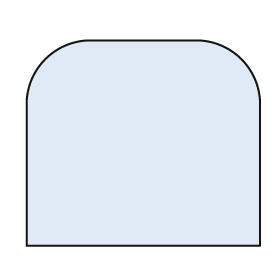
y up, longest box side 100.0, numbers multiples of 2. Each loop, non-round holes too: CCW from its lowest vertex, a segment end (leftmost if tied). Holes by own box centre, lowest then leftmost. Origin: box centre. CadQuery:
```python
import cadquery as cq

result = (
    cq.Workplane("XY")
    .moveTo(-50.0, -44.0)
    .lineTo(50.0, -44.0)
    .lineTo(50.0, 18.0)
    .threePointArc((42.0, 36.0), (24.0, 44.0))
    .lineTo(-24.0, 44.0)
    .threePointArc((-42.0, 36.0), (-50.0, 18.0))
    .close()
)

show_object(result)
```